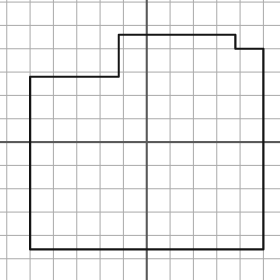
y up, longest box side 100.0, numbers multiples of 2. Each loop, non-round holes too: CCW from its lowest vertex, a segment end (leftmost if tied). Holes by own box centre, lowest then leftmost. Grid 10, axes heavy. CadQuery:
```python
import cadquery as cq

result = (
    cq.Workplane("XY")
    .moveTo(-50.0, -46.0)
    .lineTo(50.0, -46.0)
    .lineTo(50.0, 40.0)
    .lineTo(38.0, 40.0)
    .lineTo(38.0, 46.0)
    .lineTo(-12.0, 46.0)
    .lineTo(-12.0, 28.0)
    .lineTo(-50.0, 28.0)
    .close()
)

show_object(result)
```